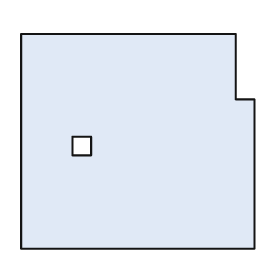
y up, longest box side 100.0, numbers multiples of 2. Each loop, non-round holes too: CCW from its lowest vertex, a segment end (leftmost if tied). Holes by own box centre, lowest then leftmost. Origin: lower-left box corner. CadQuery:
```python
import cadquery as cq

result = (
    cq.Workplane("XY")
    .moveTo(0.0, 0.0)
    .lineTo(100.0, 0.0)
    .lineTo(100.0, 64.0)
    .lineTo(92.0, 64.0)
    .lineTo(92.0, 92.0)
    .lineTo(0.0, 92.0)
    .close()
    .moveTo(22.0, 40.0)
    .lineTo(30.0, 40.0)
    .lineTo(30.0, 48.0)
    .lineTo(22.0, 48.0)
    .close()
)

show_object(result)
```